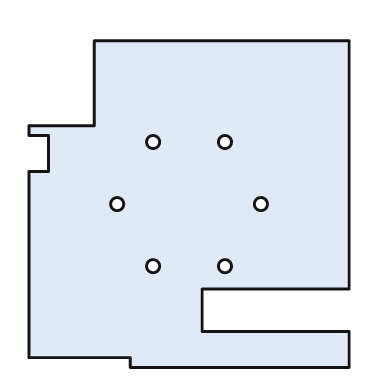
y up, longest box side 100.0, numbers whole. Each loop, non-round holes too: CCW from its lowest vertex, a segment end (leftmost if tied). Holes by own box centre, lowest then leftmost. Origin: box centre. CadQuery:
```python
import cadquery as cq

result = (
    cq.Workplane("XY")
    .moveTo(-18.0, -50.0)
    .lineTo(49.0, -50.0)
    .lineTo(49.0, -39.0)
    .lineTo(4.0, -39.0)
    .lineTo(4.0, -26.0)
    .lineTo(49.0, -26.0)
    .lineTo(49.0, 50.0)
    .lineTo(-29.0, 50.0)
    .lineTo(-29.0, 24.0)
    .lineTo(-49.0, 24.0)
    .lineTo(-49.0, 21.0)
    .lineTo(-43.0, 21.0)
    .lineTo(-43.0, 10.0)
    .lineTo(-49.0, 10.0)
    .lineTo(-49.0, -47.0)
    .lineTo(-18.0, -47.0)
    .close()
    .moveTo(-11.0, -19.0)
    .circle(2.0)
    .moveTo(11.0, -19.0)
    .circle(2.0)
    .moveTo(-22.0, 0.0)
    .circle(2.0)
    .moveTo(22.0, 0.0)
    .circle(2.0)
    .moveTo(-11.0, 19.0)
    .circle(2.0)
    .moveTo(11.0, 19.0)
    .circle(2.0)
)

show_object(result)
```